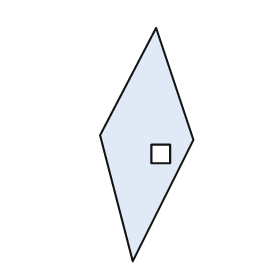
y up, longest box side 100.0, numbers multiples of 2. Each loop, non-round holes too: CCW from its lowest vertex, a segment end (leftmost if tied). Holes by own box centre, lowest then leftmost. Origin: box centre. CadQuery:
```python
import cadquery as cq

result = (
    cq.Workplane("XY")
    .moveTo(-6.0, -50.0)
    .lineTo(20.0, 2.0)
    .lineTo(4.0, 50.0)
    .lineTo(-20.0, 4.0)
    .close()
    .moveTo(2.0, -8.0)
    .lineTo(10.0, -8.0)
    .lineTo(10.0, 0.0)
    .lineTo(2.0, 0.0)
    .close()
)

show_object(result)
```